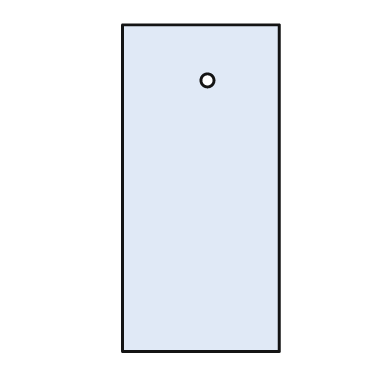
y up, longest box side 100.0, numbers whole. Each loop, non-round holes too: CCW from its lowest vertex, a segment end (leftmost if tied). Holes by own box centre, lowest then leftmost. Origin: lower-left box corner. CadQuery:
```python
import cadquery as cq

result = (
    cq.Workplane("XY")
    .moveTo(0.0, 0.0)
    .lineTo(48.0, 0.0)
    .lineTo(48.0, 100.0)
    .lineTo(0.0, 100.0)
    .close()
    .moveTo(26.0, 83.0)
    .circle(2.0)
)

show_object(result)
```